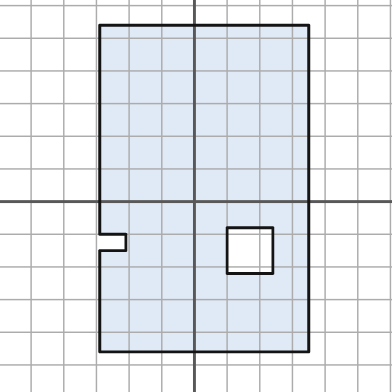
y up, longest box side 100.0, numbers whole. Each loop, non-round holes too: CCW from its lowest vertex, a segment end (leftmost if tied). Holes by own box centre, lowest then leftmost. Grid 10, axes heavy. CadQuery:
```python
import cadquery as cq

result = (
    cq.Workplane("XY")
    .moveTo(-29.0, -46.0)
    .lineTo(35.0, -46.0)
    .lineTo(35.0, 54.0)
    .lineTo(-29.0, 54.0)
    .lineTo(-29.0, -10.0)
    .lineTo(-21.0, -10.0)
    .lineTo(-21.0, -15.0)
    .lineTo(-29.0, -15.0)
    .close()
    .moveTo(10.0, -22.0)
    .lineTo(24.0, -22.0)
    .lineTo(24.0, -8.0)
    .lineTo(10.0, -8.0)
    .close()
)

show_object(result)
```